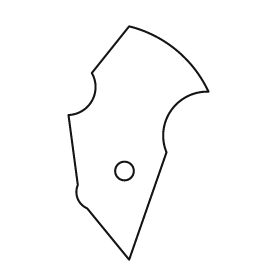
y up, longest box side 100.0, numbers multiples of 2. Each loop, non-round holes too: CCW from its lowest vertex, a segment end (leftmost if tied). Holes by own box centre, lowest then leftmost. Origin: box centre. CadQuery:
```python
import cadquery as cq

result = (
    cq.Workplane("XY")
    .moveTo(-4.0, -50.0)
    .lineTo(12.0, -4.0)
    .threePointArc((14.0, 14.0), (30.0, 22.0))
    .threePointArc((16.0, 40.0), (-4.0, 50.0))
    .lineTo(-20.0, 30.0)
    .threePointArc((-20.0, 18.0), (-30.0, 12.0))
    .lineTo(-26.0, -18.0)
    .threePointArc((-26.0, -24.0), (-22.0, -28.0))
    .close()
    .moveTo(-6.0, -12.0)
    .circle(4.0)
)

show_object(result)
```